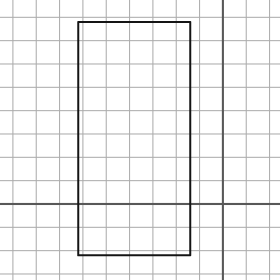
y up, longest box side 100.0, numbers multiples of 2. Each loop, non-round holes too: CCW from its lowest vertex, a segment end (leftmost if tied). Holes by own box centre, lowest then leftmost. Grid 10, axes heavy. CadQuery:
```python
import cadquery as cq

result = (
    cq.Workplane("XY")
    .moveTo(-62.0, -22.0)
    .lineTo(-14.0, -22.0)
    .lineTo(-14.0, 78.0)
    .lineTo(-62.0, 78.0)
    .close()
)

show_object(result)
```